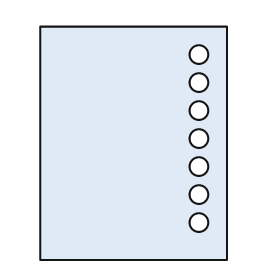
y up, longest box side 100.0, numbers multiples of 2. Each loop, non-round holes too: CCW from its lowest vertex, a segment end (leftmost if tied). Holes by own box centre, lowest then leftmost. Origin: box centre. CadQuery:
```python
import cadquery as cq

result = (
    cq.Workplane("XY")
    .moveTo(-40.0, -50.0)
    .lineTo(40.0, -50.0)
    .lineTo(40.0, 50.0)
    .lineTo(-40.0, 50.0)
    .close()
    .moveTo(28.0, -34.0)
    .circle(4.0)
    .moveTo(28.0, -22.0)
    .circle(4.0)
    .moveTo(28.0, -10.0)
    .circle(4.0)
    .moveTo(28.0, 2.0)
    .circle(4.0)
    .moveTo(28.0, 14.0)
    .circle(4.0)
    .moveTo(28.0, 26.0)
    .circle(4.0)
    .moveTo(28.0, 38.0)
    .circle(4.0)
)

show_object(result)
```